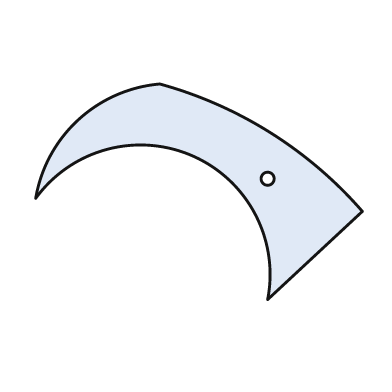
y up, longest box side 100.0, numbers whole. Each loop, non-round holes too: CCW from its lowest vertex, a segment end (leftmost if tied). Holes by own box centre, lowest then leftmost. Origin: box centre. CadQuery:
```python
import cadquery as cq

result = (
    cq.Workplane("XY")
    .moveTo(21.0, -33.0)
    .lineTo(50.0, -6.0)
    .threePointArc((22.0, 18.0), (-12.0, 33.0))
    .threePointArc((-37.0, 22.0), (-50.0, -2.0))
    .threePointArc((-2.0, 11.0), (21.0, -33.0))
    .close()
    .moveTo(21.0, 4.0)
    .circle(2.0)
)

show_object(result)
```